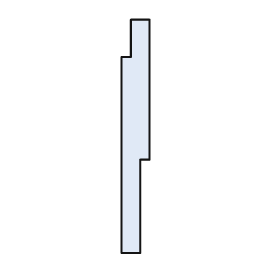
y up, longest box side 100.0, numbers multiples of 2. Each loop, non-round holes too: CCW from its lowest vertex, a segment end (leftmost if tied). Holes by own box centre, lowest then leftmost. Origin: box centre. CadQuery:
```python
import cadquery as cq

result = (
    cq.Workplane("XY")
    .moveTo(-6.0, -50.0)
    .lineTo(2.0, -50.0)
    .lineTo(2.0, -10.0)
    .lineTo(6.0, -10.0)
    .lineTo(6.0, 50.0)
    .lineTo(-2.0, 50.0)
    .lineTo(-2.0, 34.0)
    .lineTo(-6.0, 34.0)
    .close()
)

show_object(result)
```